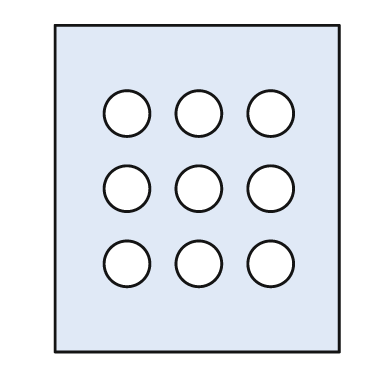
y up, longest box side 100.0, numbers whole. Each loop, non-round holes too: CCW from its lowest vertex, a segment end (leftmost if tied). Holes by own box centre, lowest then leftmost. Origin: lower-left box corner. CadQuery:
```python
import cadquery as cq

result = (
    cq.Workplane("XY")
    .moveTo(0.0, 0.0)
    .lineTo(87.0, 0.0)
    .lineTo(87.0, 100.0)
    .lineTo(0.0, 100.0)
    .close()
    .moveTo(22.0, 27.0)
    .circle(7.0)
    .moveTo(44.0, 27.0)
    .circle(7.0)
    .moveTo(66.0, 27.0)
    .circle(7.0)
    .moveTo(22.0, 50.0)
    .circle(7.0)
    .moveTo(44.0, 50.0)
    .circle(7.0)
    .moveTo(66.0, 50.0)
    .circle(7.0)
    .moveTo(22.0, 73.0)
    .circle(7.0)
    .moveTo(44.0, 73.0)
    .circle(7.0)
    .moveTo(66.0, 73.0)
    .circle(7.0)
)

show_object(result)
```